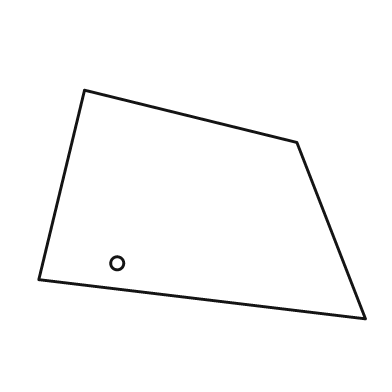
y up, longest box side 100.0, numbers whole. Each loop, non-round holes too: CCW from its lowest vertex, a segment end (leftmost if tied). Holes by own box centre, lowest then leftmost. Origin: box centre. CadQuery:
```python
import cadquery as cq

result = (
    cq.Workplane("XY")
    .moveTo(50.0, -35.0)
    .lineTo(29.0, 19.0)
    .lineTo(-36.0, 35.0)
    .lineTo(-50.0, -23.0)
    .close()
    .moveTo(-26.0, -18.0)
    .circle(2.0)
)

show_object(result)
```